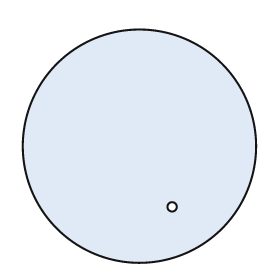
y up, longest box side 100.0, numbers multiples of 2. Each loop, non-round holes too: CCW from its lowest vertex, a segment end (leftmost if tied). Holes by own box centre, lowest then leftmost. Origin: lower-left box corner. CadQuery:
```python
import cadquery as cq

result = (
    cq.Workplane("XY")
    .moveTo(50.0, 50.0)
    .circle(50.0)
    .moveTo(64.0, 24.0)
    .circle(2.0)
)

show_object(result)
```